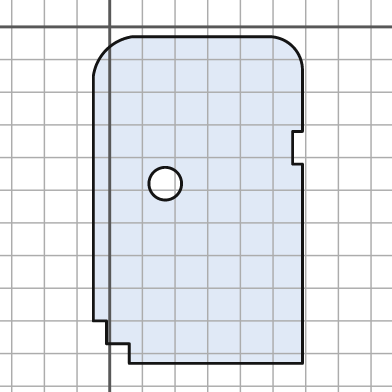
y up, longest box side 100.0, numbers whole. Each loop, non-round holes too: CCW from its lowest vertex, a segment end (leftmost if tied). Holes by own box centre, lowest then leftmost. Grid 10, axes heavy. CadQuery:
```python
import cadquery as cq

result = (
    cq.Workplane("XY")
    .moveTo(6.0, -103.0)
    .lineTo(59.0, -103.0)
    .lineTo(59.0, -42.0)
    .lineTo(56.0, -42.0)
    .lineTo(56.0, -32.0)
    .lineTo(59.0, -32.0)
    .lineTo(59.0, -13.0)
    .threePointArc((56.0, -6.0), (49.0, -3.0))
    .lineTo(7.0, -3.0)
    .threePointArc((-1.0, -7.0), (-5.0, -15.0))
    .lineTo(-5.0, -90.0)
    .lineTo(-1.0, -90.0)
    .lineTo(-1.0, -97.0)
    .lineTo(6.0, -97.0)
    .close()
    .moveTo(17.0, -48.0)
    .circle(5.0)
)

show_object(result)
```